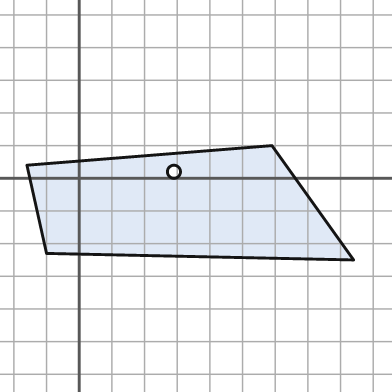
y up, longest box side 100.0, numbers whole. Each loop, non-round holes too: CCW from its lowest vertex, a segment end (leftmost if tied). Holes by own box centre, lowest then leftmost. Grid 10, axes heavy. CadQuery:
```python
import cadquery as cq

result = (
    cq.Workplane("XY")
    .moveTo(84.0, -25.0)
    .lineTo(59.0, 10.0)
    .lineTo(-16.0, 4.0)
    .lineTo(-10.0, -23.0)
    .close()
    .moveTo(29.0, 2.0)
    .circle(2.0)
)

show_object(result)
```